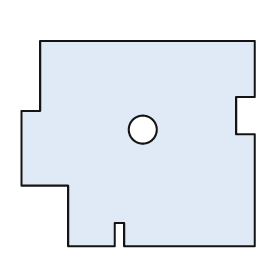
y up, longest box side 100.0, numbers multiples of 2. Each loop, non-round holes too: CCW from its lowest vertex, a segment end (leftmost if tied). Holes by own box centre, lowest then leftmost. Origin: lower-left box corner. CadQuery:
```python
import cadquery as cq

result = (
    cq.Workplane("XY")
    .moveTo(20.0, 0.0)
    .lineTo(40.0, 0.0)
    .lineTo(40.0, 10.0)
    .lineTo(44.0, 10.0)
    .lineTo(44.0, 0.0)
    .lineTo(100.0, 0.0)
    .lineTo(100.0, 48.0)
    .lineTo(92.0, 48.0)
    .lineTo(92.0, 64.0)
    .lineTo(100.0, 64.0)
    .lineTo(100.0, 88.0)
    .lineTo(8.0, 88.0)
    .lineTo(8.0, 58.0)
    .lineTo(0.0, 58.0)
    .lineTo(0.0, 26.0)
    .lineTo(20.0, 26.0)
    .close()
    .moveTo(52.0, 50.0)
    .circle(6.0)
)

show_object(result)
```